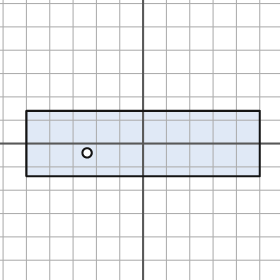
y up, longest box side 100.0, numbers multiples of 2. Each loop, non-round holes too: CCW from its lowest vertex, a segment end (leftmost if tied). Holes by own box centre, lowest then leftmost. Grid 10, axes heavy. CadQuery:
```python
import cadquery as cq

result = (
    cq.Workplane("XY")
    .moveTo(-50.0, -14.0)
    .lineTo(50.0, -14.0)
    .lineTo(50.0, 14.0)
    .lineTo(-50.0, 14.0)
    .close()
    .moveTo(-24.0, -4.0)
    .circle(2.0)
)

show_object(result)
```